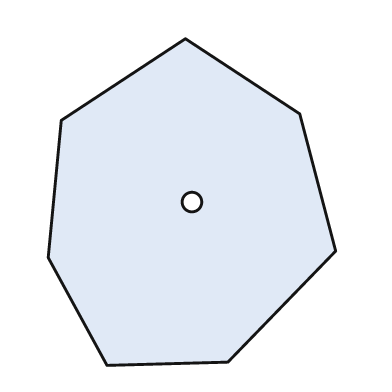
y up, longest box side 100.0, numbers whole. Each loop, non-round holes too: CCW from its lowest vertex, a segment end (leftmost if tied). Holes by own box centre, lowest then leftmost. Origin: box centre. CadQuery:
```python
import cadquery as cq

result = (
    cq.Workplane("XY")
    .moveTo(-26.0, -50.0)
    .lineTo(11.0, -49.0)
    .lineTo(44.0, -15.0)
    .lineTo(33.0, 27.0)
    .lineTo(-2.0, 50.0)
    .lineTo(-40.0, 25.0)
    .lineTo(-44.0, -17.0)
    .close()
    .moveTo(0.0, 0.0)
    .circle(3.0)
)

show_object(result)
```